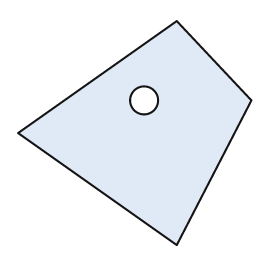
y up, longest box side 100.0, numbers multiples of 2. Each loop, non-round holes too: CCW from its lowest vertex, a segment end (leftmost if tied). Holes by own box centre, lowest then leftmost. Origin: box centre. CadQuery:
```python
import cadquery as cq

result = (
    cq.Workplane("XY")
    .moveTo(18.0, -48.0)
    .lineTo(50.0, 14.0)
    .lineTo(18.0, 48.0)
    .lineTo(-50.0, 0.0)
    .close()
    .moveTo(4.0, 14.0)
    .circle(6.0)
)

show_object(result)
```